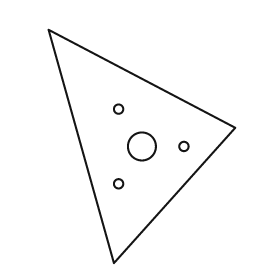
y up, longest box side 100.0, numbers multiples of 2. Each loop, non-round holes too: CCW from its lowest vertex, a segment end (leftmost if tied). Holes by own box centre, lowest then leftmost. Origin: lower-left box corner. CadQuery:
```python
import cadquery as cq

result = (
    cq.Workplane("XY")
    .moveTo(28.0, 0.0)
    .lineTo(80.0, 58.0)
    .lineTo(0.0, 100.0)
    .close()
    .moveTo(30.0, 34.0)
    .circle(2.0)
    .moveTo(40.0, 50.0)
    .circle(6.0)
    .moveTo(58.0, 50.0)
    .circle(2.0)
    .moveTo(30.0, 66.0)
    .circle(2.0)
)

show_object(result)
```